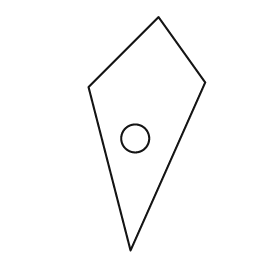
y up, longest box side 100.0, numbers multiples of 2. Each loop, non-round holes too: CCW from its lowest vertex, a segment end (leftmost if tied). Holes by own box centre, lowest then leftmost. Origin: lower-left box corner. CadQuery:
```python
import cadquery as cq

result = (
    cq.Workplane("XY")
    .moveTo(18.0, 0.0)
    .lineTo(50.0, 72.0)
    .lineTo(30.0, 100.0)
    .lineTo(0.0, 70.0)
    .close()
    .moveTo(20.0, 48.0)
    .circle(6.0)
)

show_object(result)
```